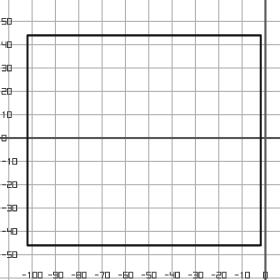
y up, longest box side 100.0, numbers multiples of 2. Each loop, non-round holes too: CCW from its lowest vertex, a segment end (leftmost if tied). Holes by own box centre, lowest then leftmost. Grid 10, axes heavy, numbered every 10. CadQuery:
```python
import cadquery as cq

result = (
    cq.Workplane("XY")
    .moveTo(-102.0, -46.0)
    .lineTo(-2.0, -46.0)
    .lineTo(-2.0, 44.0)
    .lineTo(-102.0, 44.0)
    .close()
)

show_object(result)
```